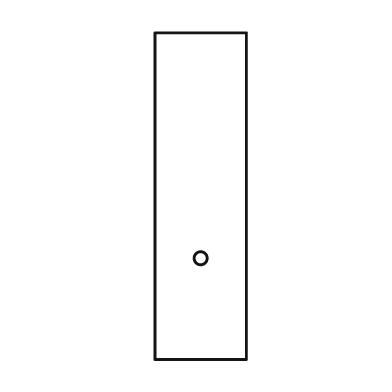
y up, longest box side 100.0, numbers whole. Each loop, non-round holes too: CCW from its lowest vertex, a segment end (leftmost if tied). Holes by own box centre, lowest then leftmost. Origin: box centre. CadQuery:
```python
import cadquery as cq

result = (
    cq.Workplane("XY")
    .moveTo(-14.0, -50.0)
    .lineTo(14.0, -50.0)
    .lineTo(14.0, 50.0)
    .lineTo(-14.0, 50.0)
    .close()
    .moveTo(0.0, -19.0)
    .circle(2.0)
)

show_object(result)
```